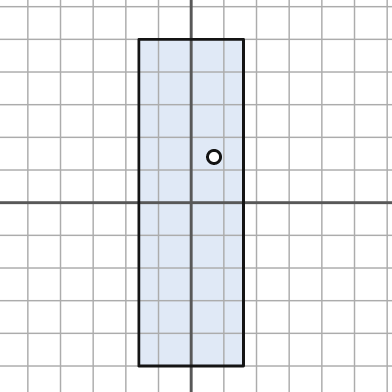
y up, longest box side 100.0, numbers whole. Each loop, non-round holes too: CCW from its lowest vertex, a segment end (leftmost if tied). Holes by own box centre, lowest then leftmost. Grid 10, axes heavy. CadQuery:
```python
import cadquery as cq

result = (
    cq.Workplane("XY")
    .moveTo(-16.0, -50.0)
    .lineTo(16.0, -50.0)
    .lineTo(16.0, 50.0)
    .lineTo(-16.0, 50.0)
    .close()
    .moveTo(7.0, 14.0)
    .circle(2.0)
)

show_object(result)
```